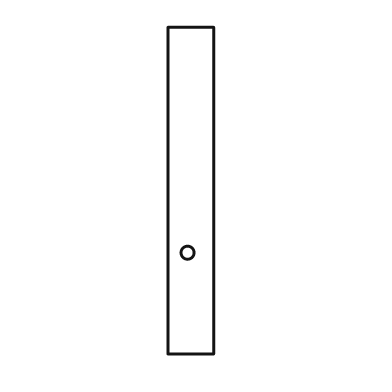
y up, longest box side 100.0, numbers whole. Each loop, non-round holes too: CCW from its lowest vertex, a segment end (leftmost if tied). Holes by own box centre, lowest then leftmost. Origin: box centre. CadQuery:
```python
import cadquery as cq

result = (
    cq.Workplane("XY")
    .moveTo(-7.0, -50.0)
    .lineTo(7.0, -50.0)
    .lineTo(7.0, 50.0)
    .lineTo(-7.0, 50.0)
    .close()
    .moveTo(-1.0, -19.0)
    .circle(2.0)
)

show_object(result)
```